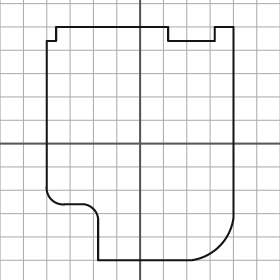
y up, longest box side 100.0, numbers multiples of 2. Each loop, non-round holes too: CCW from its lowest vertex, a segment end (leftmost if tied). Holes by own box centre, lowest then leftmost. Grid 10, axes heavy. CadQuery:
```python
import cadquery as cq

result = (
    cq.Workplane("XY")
    .moveTo(-18.0, -50.0)
    .lineTo(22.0, -50.0)
    .threePointArc((34.0, -44.0), (40.0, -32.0))
    .lineTo(40.0, 50.0)
    .lineTo(32.0, 50.0)
    .lineTo(32.0, 44.0)
    .lineTo(12.0, 44.0)
    .lineTo(12.0, 50.0)
    .lineTo(-36.0, 50.0)
    .lineTo(-36.0, 44.0)
    .lineTo(-40.0, 44.0)
    .lineTo(-40.0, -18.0)
    .threePointArc((-38.0, -24.0), (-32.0, -26.0))
    .lineTo(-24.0, -26.0)
    .threePointArc((-20.0, -28.0), (-18.0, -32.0))
    .close()
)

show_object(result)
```